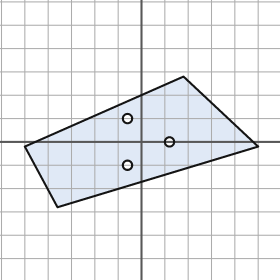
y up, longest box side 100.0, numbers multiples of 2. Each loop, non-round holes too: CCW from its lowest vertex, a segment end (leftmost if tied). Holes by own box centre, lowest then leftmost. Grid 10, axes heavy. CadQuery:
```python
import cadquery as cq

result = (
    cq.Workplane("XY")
    .moveTo(-36.0, -28.0)
    .lineTo(50.0, -2.0)
    .lineTo(18.0, 28.0)
    .lineTo(-50.0, -2.0)
    .close()
    .moveTo(-6.0, -10.0)
    .circle(2.0)
    .moveTo(12.0, 0.0)
    .circle(2.0)
    .moveTo(-6.0, 10.0)
    .circle(2.0)
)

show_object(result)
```